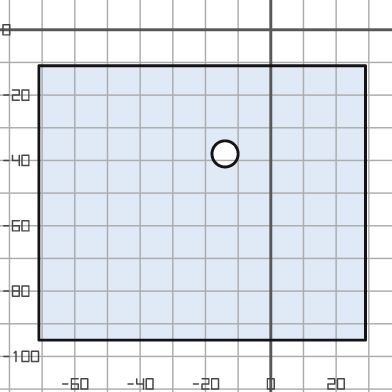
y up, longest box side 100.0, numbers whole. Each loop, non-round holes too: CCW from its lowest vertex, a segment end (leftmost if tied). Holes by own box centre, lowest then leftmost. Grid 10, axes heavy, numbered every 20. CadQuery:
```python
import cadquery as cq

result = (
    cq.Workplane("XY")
    .moveTo(-71.0, -95.0)
    .lineTo(29.0, -95.0)
    .lineTo(29.0, -11.0)
    .lineTo(-71.0, -11.0)
    .close()
    .moveTo(-14.0, -38.0)
    .circle(4.0)
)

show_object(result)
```